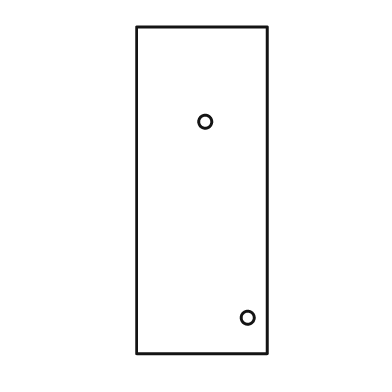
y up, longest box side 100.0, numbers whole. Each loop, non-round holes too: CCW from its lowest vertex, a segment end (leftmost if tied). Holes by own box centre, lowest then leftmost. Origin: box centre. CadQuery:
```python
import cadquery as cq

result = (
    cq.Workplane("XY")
    .moveTo(-20.0, -50.0)
    .lineTo(20.0, -50.0)
    .lineTo(20.0, 50.0)
    .lineTo(-20.0, 50.0)
    .close()
    .moveTo(14.0, -39.0)
    .circle(2.0)
    .moveTo(1.0, 21.0)
    .circle(2.0)
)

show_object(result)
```